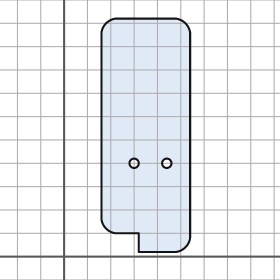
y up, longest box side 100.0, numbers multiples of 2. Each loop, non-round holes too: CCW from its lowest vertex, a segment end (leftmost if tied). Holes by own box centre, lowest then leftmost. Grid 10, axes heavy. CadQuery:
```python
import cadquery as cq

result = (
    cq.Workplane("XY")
    .moveTo(32.0, 2.0)
    .lineTo(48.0, 2.0)
    .threePointArc((52.0, 4.0), (54.0, 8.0))
    .lineTo(54.0, 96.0)
    .threePointArc((52.0, 100.0), (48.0, 102.0))
    .lineTo(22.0, 102.0)
    .threePointArc((18.0, 100.0), (16.0, 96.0))
    .lineTo(16.0, 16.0)
    .threePointArc((18.0, 12.0), (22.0, 10.0))
    .lineTo(32.0, 10.0)
    .close()
    .moveTo(30.0, 40.0)
    .circle(2.0)
    .moveTo(44.0, 40.0)
    .circle(2.0)
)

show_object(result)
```